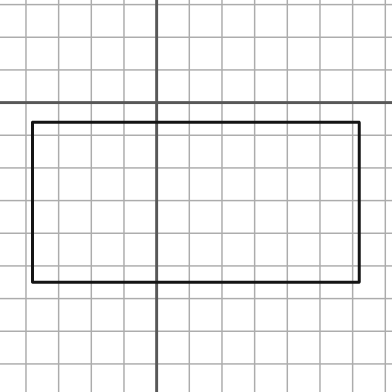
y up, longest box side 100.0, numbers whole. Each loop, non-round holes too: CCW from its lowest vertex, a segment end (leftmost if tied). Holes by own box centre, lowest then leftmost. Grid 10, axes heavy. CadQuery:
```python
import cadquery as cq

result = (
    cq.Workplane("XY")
    .moveTo(-38.0, -55.0)
    .lineTo(62.0, -55.0)
    .lineTo(62.0, -6.0)
    .lineTo(-38.0, -6.0)
    .close()
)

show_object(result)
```